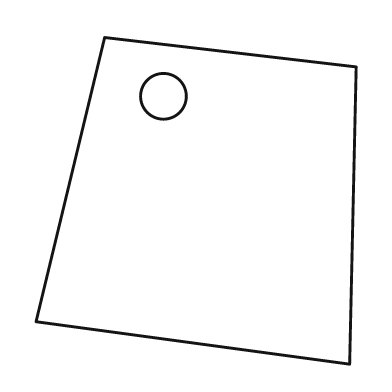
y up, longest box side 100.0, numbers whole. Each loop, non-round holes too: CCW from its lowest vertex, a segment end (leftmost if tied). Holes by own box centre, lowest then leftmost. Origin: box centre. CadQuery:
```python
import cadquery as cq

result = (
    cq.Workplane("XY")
    .moveTo(47.0, -50.0)
    .lineTo(49.0, 41.0)
    .lineTo(-28.0, 50.0)
    .lineTo(-49.0, -37.0)
    .close()
    .moveTo(-10.0, 32.0)
    .circle(7.0)
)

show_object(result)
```